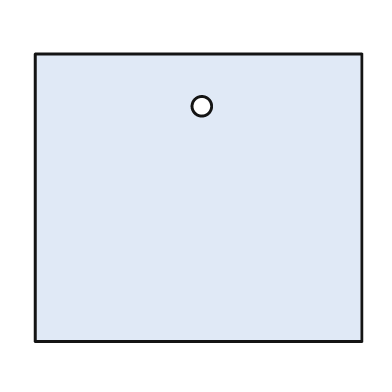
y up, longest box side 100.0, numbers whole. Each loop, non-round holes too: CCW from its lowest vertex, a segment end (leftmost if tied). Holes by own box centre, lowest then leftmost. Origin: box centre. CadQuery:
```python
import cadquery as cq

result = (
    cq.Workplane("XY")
    .moveTo(-50.0, -44.0)
    .lineTo(50.0, -44.0)
    .lineTo(50.0, 44.0)
    .lineTo(-50.0, 44.0)
    .close()
    .moveTo(1.0, 28.0)
    .circle(3.0)
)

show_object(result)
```